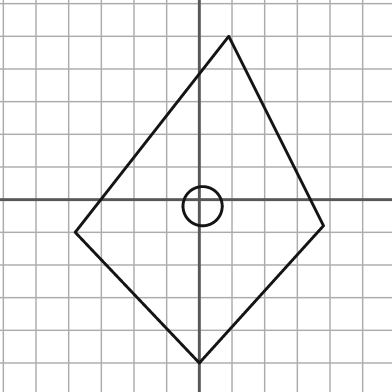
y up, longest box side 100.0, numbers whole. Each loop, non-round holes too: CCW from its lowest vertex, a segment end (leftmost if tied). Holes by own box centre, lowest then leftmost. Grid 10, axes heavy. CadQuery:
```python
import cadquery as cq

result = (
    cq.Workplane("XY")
    .moveTo(0.0, -50.0)
    .lineTo(38.0, -8.0)
    .lineTo(9.0, 50.0)
    .lineTo(-38.0, -10.0)
    .close()
    .moveTo(1.0, -2.0)
    .circle(6.0)
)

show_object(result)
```